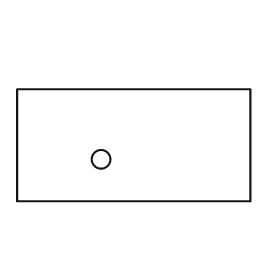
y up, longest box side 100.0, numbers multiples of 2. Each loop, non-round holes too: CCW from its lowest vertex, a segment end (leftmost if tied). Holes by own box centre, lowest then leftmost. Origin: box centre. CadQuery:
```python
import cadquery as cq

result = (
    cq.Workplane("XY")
    .moveTo(-50.0, -24.0)
    .lineTo(50.0, -24.0)
    .lineTo(50.0, 24.0)
    .lineTo(-50.0, 24.0)
    .close()
    .moveTo(-14.0, -6.0)
    .circle(4.0)
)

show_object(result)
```